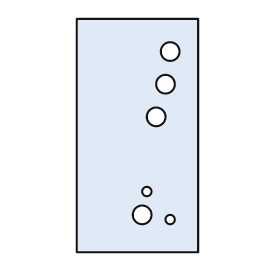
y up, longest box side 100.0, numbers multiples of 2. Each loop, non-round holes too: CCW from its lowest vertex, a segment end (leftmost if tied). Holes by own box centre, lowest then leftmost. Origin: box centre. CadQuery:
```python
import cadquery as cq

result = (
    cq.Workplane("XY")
    .moveTo(-26.0, -50.0)
    .lineTo(26.0, -50.0)
    .lineTo(26.0, 50.0)
    .lineTo(-26.0, 50.0)
    .close()
    .moveTo(14.0, -36.0)
    .circle(2.0)
    .moveTo(2.0, -34.0)
    .circle(4.0)
    .moveTo(4.0, -24.0)
    .circle(2.0)
    .moveTo(8.0, 8.0)
    .circle(4.0)
    .moveTo(12.0, 22.0)
    .circle(4.0)
    .moveTo(14.0, 36.0)
    .circle(4.0)
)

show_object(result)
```